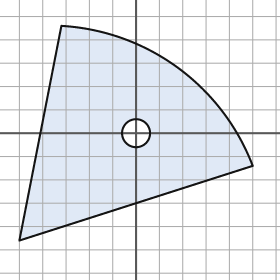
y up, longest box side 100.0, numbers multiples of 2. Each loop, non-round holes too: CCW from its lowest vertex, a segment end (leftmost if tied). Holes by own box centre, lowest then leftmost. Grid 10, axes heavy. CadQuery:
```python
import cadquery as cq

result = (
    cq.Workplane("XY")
    .moveTo(-50.0, -46.0)
    .lineTo(50.0, -14.0)
    .threePointArc((18.0, 28.0), (-32.0, 46.0))
    .close()
    .moveTo(0.0, 0.0)
    .circle(6.0)
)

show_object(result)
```